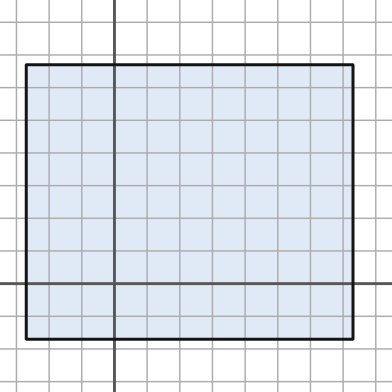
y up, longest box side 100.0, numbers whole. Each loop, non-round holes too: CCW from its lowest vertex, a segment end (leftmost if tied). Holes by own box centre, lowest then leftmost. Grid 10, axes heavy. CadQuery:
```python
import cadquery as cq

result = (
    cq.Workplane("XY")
    .moveTo(-27.0, -17.0)
    .lineTo(73.0, -17.0)
    .lineTo(73.0, 67.0)
    .lineTo(-27.0, 67.0)
    .close()
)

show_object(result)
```